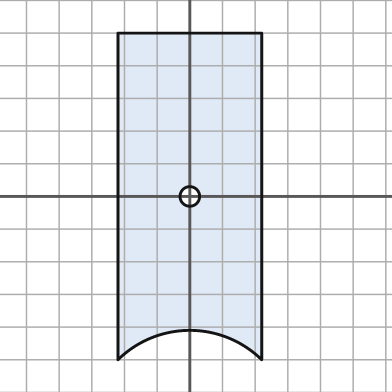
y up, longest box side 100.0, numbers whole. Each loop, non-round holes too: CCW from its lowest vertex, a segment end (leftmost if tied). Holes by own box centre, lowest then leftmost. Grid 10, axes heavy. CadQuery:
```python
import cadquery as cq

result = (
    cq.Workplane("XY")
    .moveTo(-22.0, -50.0)
    .threePointArc((0.0, -41.0), (22.0, -50.0))
    .lineTo(22.0, 50.0)
    .lineTo(-22.0, 50.0)
    .close()
    .moveTo(0.0, 0.0)
    .circle(3.0)
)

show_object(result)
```